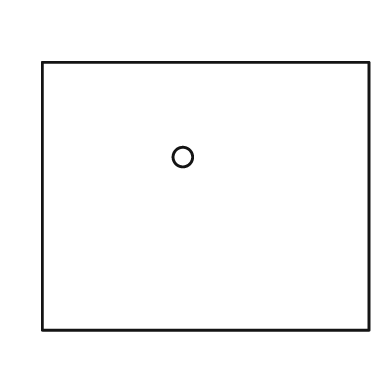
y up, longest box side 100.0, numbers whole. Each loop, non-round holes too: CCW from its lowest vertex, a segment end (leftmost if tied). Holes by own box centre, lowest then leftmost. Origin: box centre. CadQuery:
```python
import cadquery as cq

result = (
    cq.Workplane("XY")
    .moveTo(-50.0, -41.0)
    .lineTo(50.0, -41.0)
    .lineTo(50.0, 41.0)
    .lineTo(-50.0, 41.0)
    .close()
    .moveTo(-7.0, 12.0)
    .circle(3.0)
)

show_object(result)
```